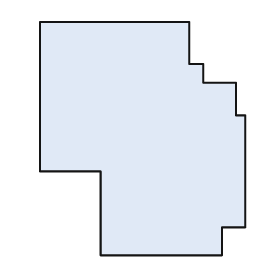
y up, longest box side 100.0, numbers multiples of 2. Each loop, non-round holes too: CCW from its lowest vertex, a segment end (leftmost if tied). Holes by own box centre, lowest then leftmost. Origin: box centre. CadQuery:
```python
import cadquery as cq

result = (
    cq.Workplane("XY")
    .moveTo(-18.0, -50.0)
    .lineTo(34.0, -50.0)
    .lineTo(34.0, -38.0)
    .lineTo(44.0, -38.0)
    .lineTo(44.0, 10.0)
    .lineTo(40.0, 10.0)
    .lineTo(40.0, 24.0)
    .lineTo(26.0, 24.0)
    .lineTo(26.0, 32.0)
    .lineTo(20.0, 32.0)
    .lineTo(20.0, 50.0)
    .lineTo(-44.0, 50.0)
    .lineTo(-44.0, -14.0)
    .lineTo(-18.0, -14.0)
    .close()
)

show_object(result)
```